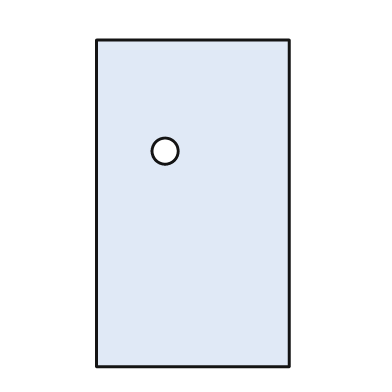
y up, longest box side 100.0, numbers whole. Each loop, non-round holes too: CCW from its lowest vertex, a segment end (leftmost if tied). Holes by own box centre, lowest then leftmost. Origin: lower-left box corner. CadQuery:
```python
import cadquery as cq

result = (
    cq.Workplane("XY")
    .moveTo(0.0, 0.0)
    .lineTo(59.0, 0.0)
    .lineTo(59.0, 100.0)
    .lineTo(0.0, 100.0)
    .close()
    .moveTo(21.0, 66.0)
    .circle(4.0)
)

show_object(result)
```